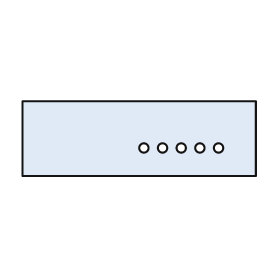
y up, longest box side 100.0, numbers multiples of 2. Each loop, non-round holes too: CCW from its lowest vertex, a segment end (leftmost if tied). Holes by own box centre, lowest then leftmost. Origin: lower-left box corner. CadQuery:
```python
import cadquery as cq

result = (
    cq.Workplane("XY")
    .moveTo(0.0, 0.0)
    .lineTo(100.0, 0.0)
    .lineTo(100.0, 32.0)
    .lineTo(0.0, 32.0)
    .close()
    .moveTo(52.0, 12.0)
    .circle(2.0)
    .moveTo(60.0, 12.0)
    .circle(2.0)
    .moveTo(68.0, 12.0)
    .circle(2.0)
    .moveTo(76.0, 12.0)
    .circle(2.0)
    .moveTo(84.0, 12.0)
    .circle(2.0)
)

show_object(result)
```